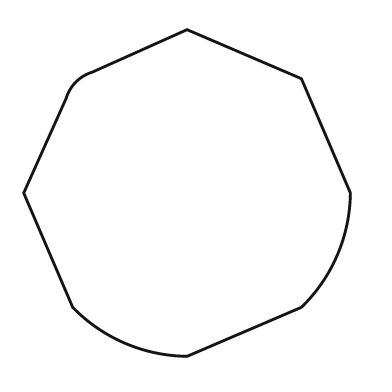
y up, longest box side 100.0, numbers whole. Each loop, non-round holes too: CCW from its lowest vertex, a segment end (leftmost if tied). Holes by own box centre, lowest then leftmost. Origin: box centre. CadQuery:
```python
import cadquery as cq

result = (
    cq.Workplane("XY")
    .moveTo(0.0, -50.0)
    .lineTo(35.0, -35.0)
    .threePointArc((46.0, -19.0), (50.0, 0.0))
    .lineTo(35.0, 35.0)
    .lineTo(0.0, 50.0)
    .lineTo(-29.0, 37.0)
    .threePointArc((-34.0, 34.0), (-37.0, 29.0))
    .lineTo(-50.0, 0.0)
    .lineTo(-35.0, -35.0)
    .threePointArc((-19.0, -46.0), (0.0, -50.0))
    .close()
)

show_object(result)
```